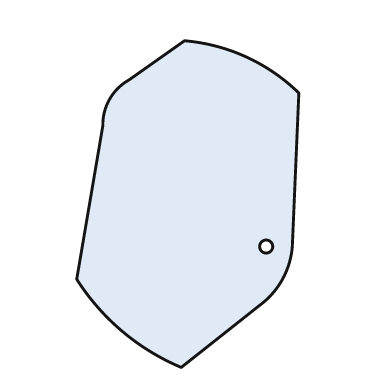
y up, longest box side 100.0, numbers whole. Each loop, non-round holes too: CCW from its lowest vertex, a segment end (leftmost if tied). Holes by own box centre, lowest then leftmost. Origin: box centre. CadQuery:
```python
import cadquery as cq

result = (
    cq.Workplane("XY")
    .moveTo(-2.0, -50.0)
    .lineTo(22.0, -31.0)
    .threePointArc((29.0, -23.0), (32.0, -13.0))
    .lineTo(34.0, 34.0)
    .threePointArc((18.0, 45.0), (-1.0, 50.0))
    .lineTo(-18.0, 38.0)
    .threePointArc((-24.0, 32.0), (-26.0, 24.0))
    .lineTo(-34.0, -23.0)
    .threePointArc((-20.0, -39.0), (-2.0, -50.0))
    .close()
    .moveTo(24.0, -13.0)
    .circle(2.0)
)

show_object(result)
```